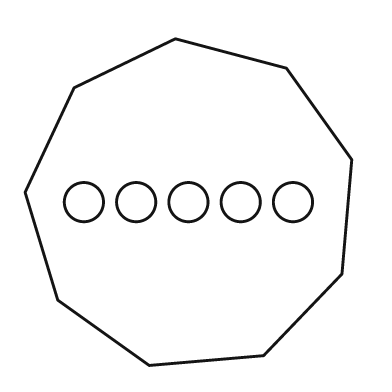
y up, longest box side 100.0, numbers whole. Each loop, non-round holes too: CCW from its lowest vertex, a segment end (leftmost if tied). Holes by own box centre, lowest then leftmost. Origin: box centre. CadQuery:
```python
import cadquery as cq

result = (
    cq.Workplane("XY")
    .moveTo(-12.0, -50.0)
    .lineTo(23.0, -47.0)
    .lineTo(47.0, -22.0)
    .lineTo(50.0, 13.0)
    .lineTo(30.0, 41.0)
    .lineTo(-4.0, 50.0)
    .lineTo(-35.0, 35.0)
    .lineTo(-50.0, 3.0)
    .lineTo(-40.0, -30.0)
    .close()
    .moveTo(-32.0, 0.0)
    .circle(6.0)
    .moveTo(-16.0, 0.0)
    .circle(6.0)
    .moveTo(0.0, 0.0)
    .circle(6.0)
    .moveTo(16.0, 0.0)
    .circle(6.0)
    .moveTo(32.0, 0.0)
    .circle(6.0)
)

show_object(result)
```